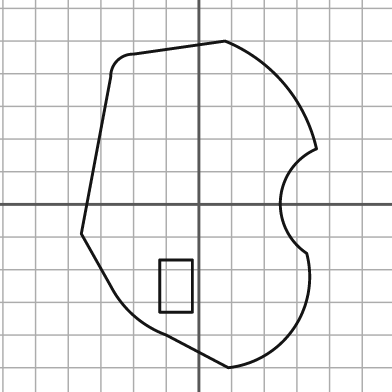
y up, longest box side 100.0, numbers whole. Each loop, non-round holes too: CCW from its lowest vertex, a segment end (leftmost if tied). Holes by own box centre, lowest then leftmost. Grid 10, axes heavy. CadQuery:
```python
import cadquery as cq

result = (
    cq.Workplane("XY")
    .moveTo(9.0, -50.0)
    .threePointArc((29.0, -38.0), (33.0, -15.0))
    .threePointArc((25.0, 2.0), (36.0, 17.0))
    .threePointArc((26.0, 37.0), (8.0, 50.0))
    .lineTo(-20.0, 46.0)
    .threePointArc((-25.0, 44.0), (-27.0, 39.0))
    .lineTo(-36.0, -9.0)
    .lineTo(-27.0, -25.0)
    .threePointArc((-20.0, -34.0), (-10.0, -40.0))
    .close()
    .moveTo(-12.0, -33.0)
    .lineTo(-2.0, -33.0)
    .lineTo(-2.0, -17.0)
    .lineTo(-12.0, -17.0)
    .close()
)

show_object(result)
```